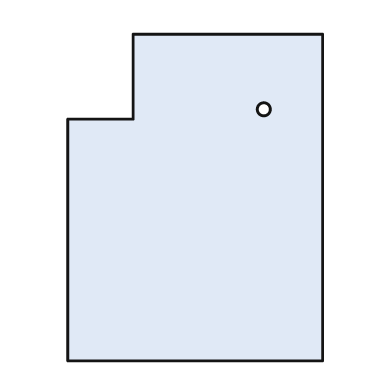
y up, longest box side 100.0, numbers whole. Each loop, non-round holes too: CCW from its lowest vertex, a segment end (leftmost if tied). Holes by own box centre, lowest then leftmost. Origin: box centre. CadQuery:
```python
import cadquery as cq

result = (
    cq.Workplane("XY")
    .moveTo(-39.0, -50.0)
    .lineTo(39.0, -50.0)
    .lineTo(39.0, 50.0)
    .lineTo(-19.0, 50.0)
    .lineTo(-19.0, 24.0)
    .lineTo(-39.0, 24.0)
    .close()
    .moveTo(21.0, 27.0)
    .circle(2.0)
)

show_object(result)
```